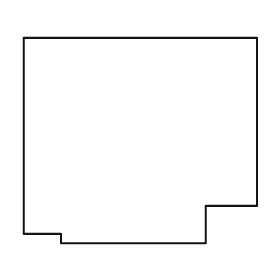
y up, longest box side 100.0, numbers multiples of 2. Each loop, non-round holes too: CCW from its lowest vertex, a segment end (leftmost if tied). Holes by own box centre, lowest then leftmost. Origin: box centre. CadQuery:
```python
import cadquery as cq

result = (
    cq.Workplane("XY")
    .moveTo(-34.0, -44.0)
    .lineTo(28.0, -44.0)
    .lineTo(28.0, -28.0)
    .lineTo(50.0, -28.0)
    .lineTo(50.0, 44.0)
    .lineTo(-50.0, 44.0)
    .lineTo(-50.0, -40.0)
    .lineTo(-34.0, -40.0)
    .close()
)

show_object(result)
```